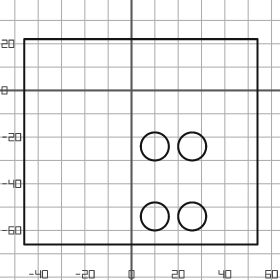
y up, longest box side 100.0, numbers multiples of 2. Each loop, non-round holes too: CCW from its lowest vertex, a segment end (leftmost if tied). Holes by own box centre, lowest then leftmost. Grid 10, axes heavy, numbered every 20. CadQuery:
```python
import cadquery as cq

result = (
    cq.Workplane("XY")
    .moveTo(-46.0, -66.0)
    .lineTo(54.0, -66.0)
    .lineTo(54.0, 22.0)
    .lineTo(-46.0, 22.0)
    .close()
    .moveTo(10.0, -54.0)
    .circle(6.0)
    .moveTo(26.0, -54.0)
    .circle(6.0)
    .moveTo(10.0, -24.0)
    .circle(6.0)
    .moveTo(26.0, -24.0)
    .circle(6.0)
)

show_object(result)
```